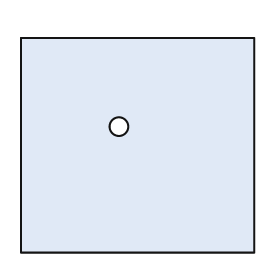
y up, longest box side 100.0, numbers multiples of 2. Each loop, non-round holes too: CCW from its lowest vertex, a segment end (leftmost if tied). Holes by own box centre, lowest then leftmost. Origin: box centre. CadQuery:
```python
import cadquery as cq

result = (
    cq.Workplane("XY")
    .moveTo(-50.0, -46.0)
    .lineTo(50.0, -46.0)
    .lineTo(50.0, 46.0)
    .lineTo(-50.0, 46.0)
    .close()
    .moveTo(-8.0, 8.0)
    .circle(4.0)
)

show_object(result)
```